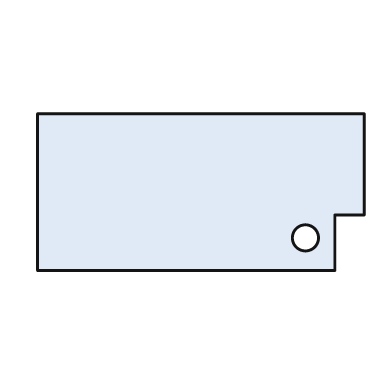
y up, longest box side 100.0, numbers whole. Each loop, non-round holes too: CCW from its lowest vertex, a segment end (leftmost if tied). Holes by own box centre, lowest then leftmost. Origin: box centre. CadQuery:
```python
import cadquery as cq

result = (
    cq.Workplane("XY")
    .moveTo(-50.0, -24.0)
    .lineTo(41.0, -24.0)
    .lineTo(41.0, -7.0)
    .lineTo(50.0, -7.0)
    .lineTo(50.0, 24.0)
    .lineTo(-50.0, 24.0)
    .close()
    .moveTo(32.0, -14.0)
    .circle(4.0)
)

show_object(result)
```